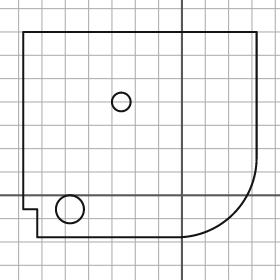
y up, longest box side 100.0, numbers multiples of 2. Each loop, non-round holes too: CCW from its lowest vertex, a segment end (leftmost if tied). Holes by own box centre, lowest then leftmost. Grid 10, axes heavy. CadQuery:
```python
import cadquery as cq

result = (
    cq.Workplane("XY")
    .moveTo(-62.0, -18.0)
    .lineTo(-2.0, -18.0)
    .threePointArc((22.0, -8.0), (32.0, 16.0))
    .lineTo(32.0, 70.0)
    .lineTo(-68.0, 70.0)
    .lineTo(-68.0, -6.0)
    .lineTo(-62.0, -6.0)
    .close()
    .moveTo(-48.0, -6.0)
    .circle(6.0)
    .moveTo(-26.0, 40.0)
    .circle(4.0)
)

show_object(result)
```